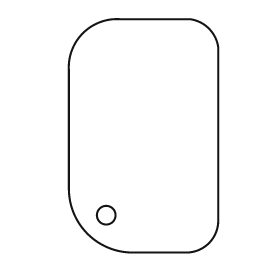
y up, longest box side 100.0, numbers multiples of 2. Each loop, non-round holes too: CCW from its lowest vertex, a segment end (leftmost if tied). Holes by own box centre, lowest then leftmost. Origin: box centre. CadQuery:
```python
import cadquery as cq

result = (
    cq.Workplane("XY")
    .moveTo(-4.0, -50.0)
    .lineTo(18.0, -50.0)
    .threePointArc((28.0, -46.0), (32.0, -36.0))
    .lineTo(32.0, 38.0)
    .threePointArc((28.0, 46.0), (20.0, 50.0))
    .lineTo(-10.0, 50.0)
    .threePointArc((-26.0, 44.0), (-32.0, 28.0))
    .lineTo(-32.0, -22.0)
    .threePointArc((-24.0, -42.0), (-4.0, -50.0))
    .close()
    .moveTo(-16.0, -34.0)
    .circle(4.0)
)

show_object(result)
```